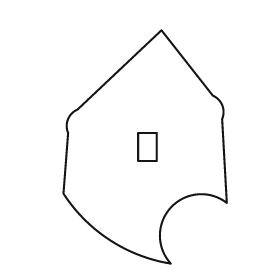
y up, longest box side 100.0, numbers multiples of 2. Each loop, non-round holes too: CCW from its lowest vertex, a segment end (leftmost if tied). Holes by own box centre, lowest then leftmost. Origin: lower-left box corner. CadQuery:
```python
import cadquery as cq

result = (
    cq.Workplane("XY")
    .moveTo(46.0, 0.0)
    .threePointArc((46.0, 24.0), (70.0, 26.0))
    .lineTo(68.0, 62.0)
    .threePointArc((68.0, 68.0), (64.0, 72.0))
    .lineTo(42.0, 100.0)
    .lineTo(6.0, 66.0)
    .threePointArc((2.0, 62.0), (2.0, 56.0))
    .lineTo(0.0, 30.0)
    .threePointArc((20.0, 10.0), (46.0, 0.0))
    .close()
    .moveTo(32.0, 44.0)
    .lineTo(40.0, 44.0)
    .lineTo(40.0, 56.0)
    .lineTo(32.0, 56.0)
    .close()
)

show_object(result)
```